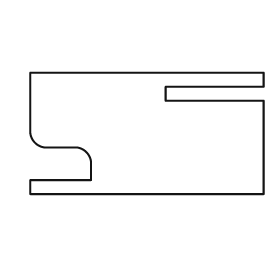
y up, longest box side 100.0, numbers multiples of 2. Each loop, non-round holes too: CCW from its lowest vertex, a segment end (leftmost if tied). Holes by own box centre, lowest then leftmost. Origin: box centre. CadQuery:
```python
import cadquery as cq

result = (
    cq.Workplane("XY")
    .moveTo(-50.0, -26.0)
    .lineTo(50.0, -26.0)
    .lineTo(50.0, 14.0)
    .lineTo(8.0, 14.0)
    .lineTo(8.0, 20.0)
    .lineTo(50.0, 20.0)
    .lineTo(50.0, 26.0)
    .lineTo(-50.0, 26.0)
    .lineTo(-50.0, 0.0)
    .threePointArc((-48.0, -4.0), (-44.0, -6.0))
    .lineTo(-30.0, -6.0)
    .threePointArc((-26.0, -8.0), (-24.0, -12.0))
    .lineTo(-24.0, -20.0)
    .lineTo(-50.0, -20.0)
    .close()
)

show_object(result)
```